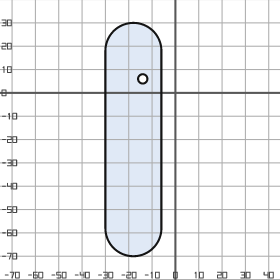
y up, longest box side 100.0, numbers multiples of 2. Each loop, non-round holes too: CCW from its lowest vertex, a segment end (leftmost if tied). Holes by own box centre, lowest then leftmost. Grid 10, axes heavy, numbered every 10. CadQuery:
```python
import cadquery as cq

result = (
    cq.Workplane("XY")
    .moveTo(-30.0, -58.0)
    .threePointArc((-18.0, -70.0), (-6.0, -58.0))
    .lineTo(-6.0, 18.0)
    .threePointArc((-18.0, 30.0), (-30.0, 18.0))
    .close()
    .moveTo(-14.0, 6.0)
    .circle(2.0)
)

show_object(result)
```